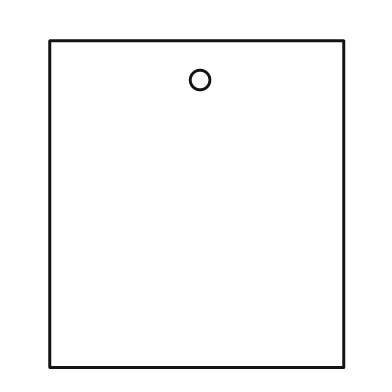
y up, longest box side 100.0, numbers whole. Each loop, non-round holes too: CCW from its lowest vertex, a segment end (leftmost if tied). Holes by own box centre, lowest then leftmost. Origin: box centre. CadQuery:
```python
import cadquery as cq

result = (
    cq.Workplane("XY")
    .moveTo(-45.0, -50.0)
    .lineTo(45.0, -50.0)
    .lineTo(45.0, 50.0)
    .lineTo(-45.0, 50.0)
    .close()
    .moveTo(1.0, 38.0)
    .circle(3.0)
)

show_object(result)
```